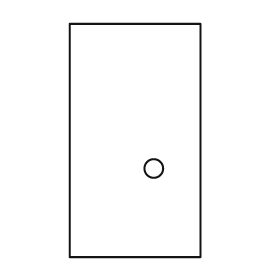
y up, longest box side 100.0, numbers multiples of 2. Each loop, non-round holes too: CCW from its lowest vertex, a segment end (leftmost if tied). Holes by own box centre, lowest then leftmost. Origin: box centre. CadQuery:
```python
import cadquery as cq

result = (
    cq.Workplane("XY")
    .moveTo(-28.0, -50.0)
    .lineTo(28.0, -50.0)
    .lineTo(28.0, 50.0)
    .lineTo(-28.0, 50.0)
    .close()
    .moveTo(8.0, -12.0)
    .circle(4.0)
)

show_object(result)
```